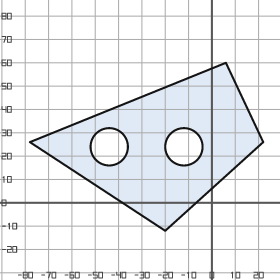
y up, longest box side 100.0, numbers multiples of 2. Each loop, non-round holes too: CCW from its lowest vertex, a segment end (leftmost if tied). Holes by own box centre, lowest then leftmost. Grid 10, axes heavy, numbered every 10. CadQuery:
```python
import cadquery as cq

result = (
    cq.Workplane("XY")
    .moveTo(-20.0, -12.0)
    .lineTo(22.0, 26.0)
    .lineTo(6.0, 60.0)
    .lineTo(-78.0, 26.0)
    .close()
    .moveTo(-44.0, 24.0)
    .circle(8.0)
    .moveTo(-12.0, 24.0)
    .circle(8.0)
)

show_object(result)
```